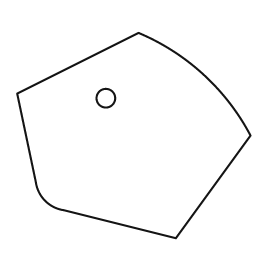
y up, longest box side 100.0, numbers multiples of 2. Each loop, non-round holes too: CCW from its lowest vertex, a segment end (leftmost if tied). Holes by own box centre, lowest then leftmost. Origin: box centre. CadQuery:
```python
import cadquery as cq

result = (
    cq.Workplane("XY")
    .moveTo(18.0, -44.0)
    .lineTo(50.0, 0.0)
    .threePointArc((30.0, 26.0), (2.0, 44.0))
    .lineTo(-50.0, 18.0)
    .lineTo(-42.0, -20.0)
    .threePointArc((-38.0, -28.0), (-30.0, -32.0))
    .close()
    .moveTo(-12.0, 16.0)
    .circle(4.0)
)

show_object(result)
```